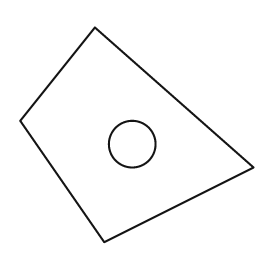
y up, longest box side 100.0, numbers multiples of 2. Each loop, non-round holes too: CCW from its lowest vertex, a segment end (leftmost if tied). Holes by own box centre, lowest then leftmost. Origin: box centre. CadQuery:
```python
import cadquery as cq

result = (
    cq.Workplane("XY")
    .moveTo(-14.0, -46.0)
    .lineTo(50.0, -14.0)
    .lineTo(-18.0, 46.0)
    .lineTo(-50.0, 6.0)
    .close()
    .moveTo(-2.0, -4.0)
    .circle(10.0)
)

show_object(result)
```